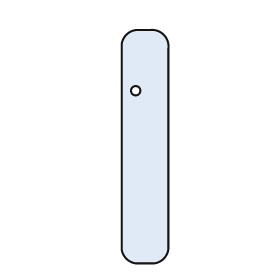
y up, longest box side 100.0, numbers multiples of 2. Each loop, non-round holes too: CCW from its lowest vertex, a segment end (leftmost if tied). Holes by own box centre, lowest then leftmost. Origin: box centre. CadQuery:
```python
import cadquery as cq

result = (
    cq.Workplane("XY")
    .moveTo(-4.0, -50.0)
    .lineTo(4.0, -50.0)
    .threePointArc((8.0, -48.0), (10.0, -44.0))
    .lineTo(10.0, 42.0)
    .threePointArc((8.0, 48.0), (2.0, 50.0))
    .lineTo(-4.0, 50.0)
    .threePointArc((-8.0, 48.0), (-10.0, 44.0))
    .lineTo(-10.0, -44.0)
    .threePointArc((-8.0, -48.0), (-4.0, -50.0))
    .close()
    .moveTo(-4.0, 24.0)
    .circle(2.0)
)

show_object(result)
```